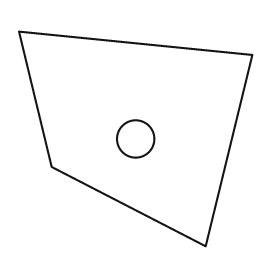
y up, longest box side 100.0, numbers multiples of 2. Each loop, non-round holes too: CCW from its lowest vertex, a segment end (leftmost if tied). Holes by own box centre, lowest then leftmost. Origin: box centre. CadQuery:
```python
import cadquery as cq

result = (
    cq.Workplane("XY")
    .moveTo(30.0, -46.0)
    .lineTo(50.0, 36.0)
    .lineTo(-50.0, 46.0)
    .lineTo(-36.0, -12.0)
    .close()
    .moveTo(0.0, 0.0)
    .circle(8.0)
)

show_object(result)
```